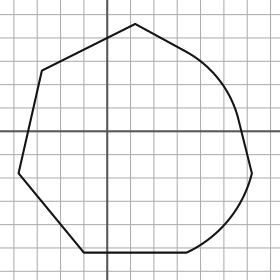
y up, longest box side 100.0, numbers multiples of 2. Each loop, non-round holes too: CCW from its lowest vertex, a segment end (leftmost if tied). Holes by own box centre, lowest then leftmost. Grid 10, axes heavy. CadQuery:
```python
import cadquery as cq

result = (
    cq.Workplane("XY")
    .moveTo(-10.0, -52.0)
    .lineTo(34.0, -52.0)
    .threePointArc((52.0, -38.0), (62.0, -18.0))
    .lineTo(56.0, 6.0)
    .threePointArc((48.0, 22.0), (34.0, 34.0))
    .lineTo(12.0, 46.0)
    .lineTo(-28.0, 26.0)
    .lineTo(-38.0, -18.0)
    .close()
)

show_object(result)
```